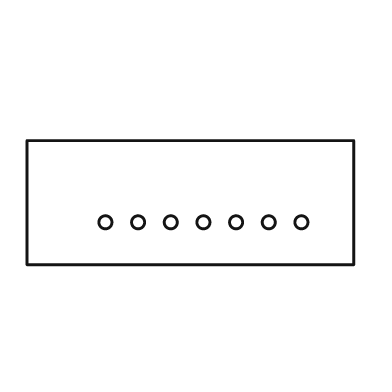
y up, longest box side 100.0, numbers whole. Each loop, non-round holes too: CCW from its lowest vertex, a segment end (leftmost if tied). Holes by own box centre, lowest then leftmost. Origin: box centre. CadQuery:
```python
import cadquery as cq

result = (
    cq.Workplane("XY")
    .moveTo(-50.0, -19.0)
    .lineTo(50.0, -19.0)
    .lineTo(50.0, 19.0)
    .lineTo(-50.0, 19.0)
    .close()
    .moveTo(-26.0, -6.0)
    .circle(2.0)
    .moveTo(-16.0, -6.0)
    .circle(2.0)
    .moveTo(-6.0, -6.0)
    .circle(2.0)
    .moveTo(4.0, -6.0)
    .circle(2.0)
    .moveTo(14.0, -6.0)
    .circle(2.0)
    .moveTo(24.0, -6.0)
    .circle(2.0)
    .moveTo(34.0, -6.0)
    .circle(2.0)
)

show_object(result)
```